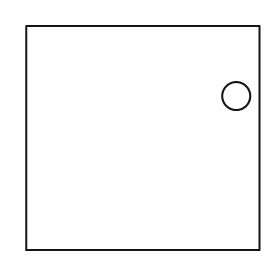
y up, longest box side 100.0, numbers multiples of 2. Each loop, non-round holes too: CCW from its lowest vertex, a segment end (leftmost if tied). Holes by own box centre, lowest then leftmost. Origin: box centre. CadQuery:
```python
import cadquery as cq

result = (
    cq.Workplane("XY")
    .moveTo(-50.0, -48.0)
    .lineTo(50.0, -48.0)
    .lineTo(50.0, 48.0)
    .lineTo(-50.0, 48.0)
    .close()
    .moveTo(40.0, 18.0)
    .circle(6.0)
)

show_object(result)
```